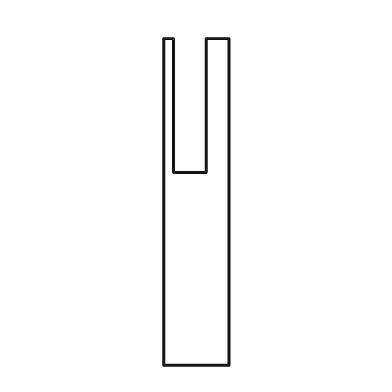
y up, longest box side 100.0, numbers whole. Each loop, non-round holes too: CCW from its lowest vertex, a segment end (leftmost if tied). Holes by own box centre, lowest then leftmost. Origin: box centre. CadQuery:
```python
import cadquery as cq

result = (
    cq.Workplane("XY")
    .moveTo(-10.0, -50.0)
    .lineTo(10.0, -50.0)
    .lineTo(10.0, 50.0)
    .lineTo(3.0, 50.0)
    .lineTo(3.0, 9.0)
    .lineTo(-7.0, 9.0)
    .lineTo(-7.0, 50.0)
    .lineTo(-10.0, 50.0)
    .close()
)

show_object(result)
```